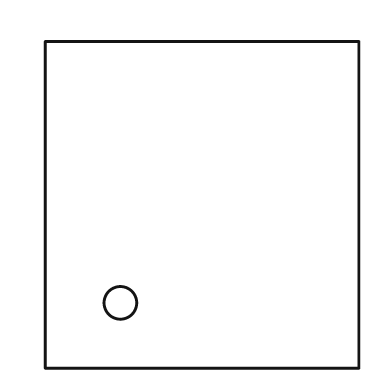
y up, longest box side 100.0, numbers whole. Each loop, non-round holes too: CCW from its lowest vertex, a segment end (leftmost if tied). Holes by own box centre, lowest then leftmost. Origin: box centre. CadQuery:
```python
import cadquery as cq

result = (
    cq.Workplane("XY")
    .moveTo(-48.0, -50.0)
    .lineTo(48.0, -50.0)
    .lineTo(48.0, 50.0)
    .lineTo(-48.0, 50.0)
    .close()
    .moveTo(-25.0, -30.0)
    .circle(5.0)
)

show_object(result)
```